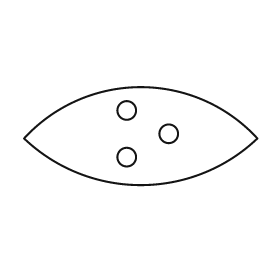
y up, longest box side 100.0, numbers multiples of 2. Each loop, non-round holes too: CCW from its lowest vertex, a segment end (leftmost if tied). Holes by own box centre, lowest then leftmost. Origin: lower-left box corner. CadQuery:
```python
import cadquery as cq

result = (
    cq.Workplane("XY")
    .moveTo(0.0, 20.0)
    .threePointArc((50.0, 0.0), (100.0, 20.0))
    .threePointArc((50.0, 42.0), (0.0, 20.0))
    .close()
    .moveTo(44.0, 12.0)
    .circle(4.0)
    .moveTo(62.0, 22.0)
    .circle(4.0)
    .moveTo(44.0, 32.0)
    .circle(4.0)
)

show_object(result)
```